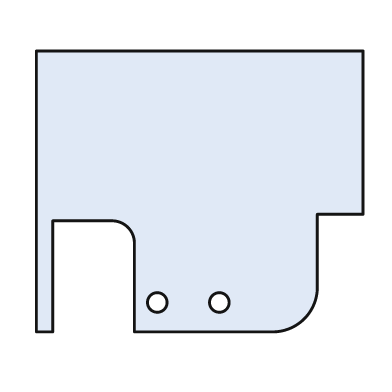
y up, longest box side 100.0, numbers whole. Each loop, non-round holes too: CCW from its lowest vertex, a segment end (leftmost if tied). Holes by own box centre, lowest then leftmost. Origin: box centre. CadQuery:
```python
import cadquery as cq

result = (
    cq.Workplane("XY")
    .moveTo(-50.0, -43.0)
    .lineTo(-45.0, -43.0)
    .lineTo(-45.0, -9.0)
    .lineTo(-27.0, -9.0)
    .threePointArc((-22.0, -11.0), (-20.0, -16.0))
    .lineTo(-20.0, -43.0)
    .lineTo(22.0, -43.0)
    .threePointArc((32.0, -39.0), (36.0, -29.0))
    .lineTo(36.0, -7.0)
    .lineTo(50.0, -7.0)
    .lineTo(50.0, 43.0)
    .lineTo(-50.0, 43.0)
    .close()
    .moveTo(-13.0, -34.0)
    .circle(3.0)
    .moveTo(6.0, -34.0)
    .circle(3.0)
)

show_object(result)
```